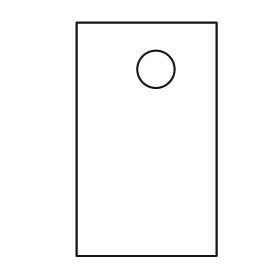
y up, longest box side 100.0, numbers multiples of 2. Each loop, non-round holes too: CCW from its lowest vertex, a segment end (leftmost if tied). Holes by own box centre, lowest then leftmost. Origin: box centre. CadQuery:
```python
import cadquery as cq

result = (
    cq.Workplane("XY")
    .moveTo(-30.0, -50.0)
    .lineTo(30.0, -50.0)
    .lineTo(30.0, 50.0)
    .lineTo(-30.0, 50.0)
    .close()
    .moveTo(4.0, 30.0)
    .circle(8.0)
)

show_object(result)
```